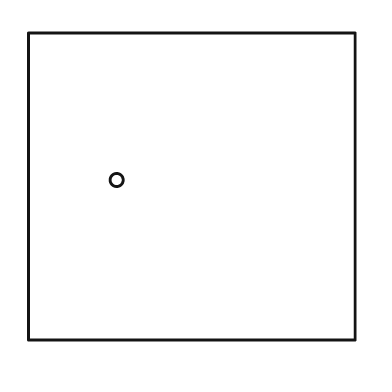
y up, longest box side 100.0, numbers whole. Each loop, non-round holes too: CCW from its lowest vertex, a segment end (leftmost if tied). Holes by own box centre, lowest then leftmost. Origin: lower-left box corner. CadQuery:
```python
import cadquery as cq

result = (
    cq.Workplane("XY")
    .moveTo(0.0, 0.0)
    .lineTo(100.0, 0.0)
    .lineTo(100.0, 94.0)
    .lineTo(0.0, 94.0)
    .close()
    .moveTo(27.0, 49.0)
    .circle(2.0)
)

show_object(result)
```